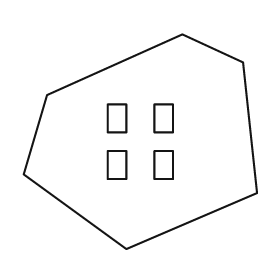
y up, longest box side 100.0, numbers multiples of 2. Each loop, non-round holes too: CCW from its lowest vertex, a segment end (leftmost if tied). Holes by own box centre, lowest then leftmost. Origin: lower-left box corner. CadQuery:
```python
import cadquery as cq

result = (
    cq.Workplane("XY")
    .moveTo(44.0, 0.0)
    .lineTo(100.0, 24.0)
    .lineTo(94.0, 80.0)
    .lineTo(68.0, 92.0)
    .lineTo(10.0, 66.0)
    .lineTo(0.0, 32.0)
    .close()
    .moveTo(36.0, 30.0)
    .lineTo(44.0, 30.0)
    .lineTo(44.0, 42.0)
    .lineTo(36.0, 42.0)
    .close()
    .moveTo(56.0, 30.0)
    .lineTo(64.0, 30.0)
    .lineTo(64.0, 42.0)
    .lineTo(56.0, 42.0)
    .close()
    .moveTo(36.0, 50.0)
    .lineTo(44.0, 50.0)
    .lineTo(44.0, 62.0)
    .lineTo(36.0, 62.0)
    .close()
    .moveTo(56.0, 50.0)
    .lineTo(64.0, 50.0)
    .lineTo(64.0, 62.0)
    .lineTo(56.0, 62.0)
    .close()
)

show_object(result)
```